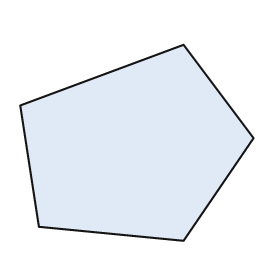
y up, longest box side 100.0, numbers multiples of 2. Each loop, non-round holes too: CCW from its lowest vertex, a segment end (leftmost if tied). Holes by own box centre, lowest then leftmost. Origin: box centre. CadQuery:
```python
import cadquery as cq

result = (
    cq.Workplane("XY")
    .moveTo(20.0, -42.0)
    .lineTo(50.0, 2.0)
    .lineTo(20.0, 42.0)
    .lineTo(-50.0, 16.0)
    .lineTo(-42.0, -36.0)
    .close()
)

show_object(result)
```